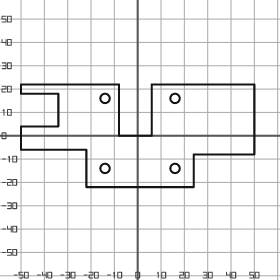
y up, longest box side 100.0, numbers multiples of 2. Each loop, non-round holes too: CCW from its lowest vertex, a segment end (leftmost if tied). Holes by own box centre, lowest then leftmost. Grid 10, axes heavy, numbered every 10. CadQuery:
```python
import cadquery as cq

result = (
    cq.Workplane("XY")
    .moveTo(-22.0, -22.0)
    .lineTo(24.0, -22.0)
    .lineTo(24.0, -8.0)
    .lineTo(50.0, -8.0)
    .lineTo(50.0, 22.0)
    .lineTo(6.0, 22.0)
    .lineTo(6.0, 0.0)
    .lineTo(-8.0, 0.0)
    .lineTo(-8.0, 22.0)
    .lineTo(-50.0, 22.0)
    .lineTo(-50.0, 18.0)
    .lineTo(-34.0, 18.0)
    .lineTo(-34.0, 4.0)
    .lineTo(-50.0, 4.0)
    .lineTo(-50.0, -6.0)
    .lineTo(-22.0, -6.0)
    .close()
    .moveTo(-14.0, -14.0)
    .circle(2.0)
    .moveTo(16.0, -14.0)
    .circle(2.0)
    .moveTo(-14.0, 16.0)
    .circle(2.0)
    .moveTo(16.0, 16.0)
    .circle(2.0)
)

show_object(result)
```